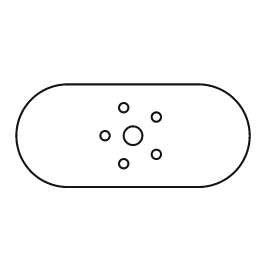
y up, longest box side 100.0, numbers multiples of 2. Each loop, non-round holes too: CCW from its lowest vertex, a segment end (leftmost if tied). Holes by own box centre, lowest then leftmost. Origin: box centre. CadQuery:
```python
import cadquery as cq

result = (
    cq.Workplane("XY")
    .moveTo(-28.0, -22.0)
    .lineTo(28.0, -22.0)
    .threePointArc((50.0, 0.0), (28.0, 22.0))
    .lineTo(-28.0, 22.0)
    .threePointArc((-50.0, 0.0), (-28.0, -22.0))
    .close()
    .moveTo(-4.0, -12.0)
    .circle(2.0)
    .moveTo(10.0, -8.0)
    .circle(2.0)
    .moveTo(-12.0, 0.0)
    .circle(2.0)
    .moveTo(0.0, 0.0)
    .circle(4.0)
    .moveTo(10.0, 8.0)
    .circle(2.0)
    .moveTo(-4.0, 12.0)
    .circle(2.0)
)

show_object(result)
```